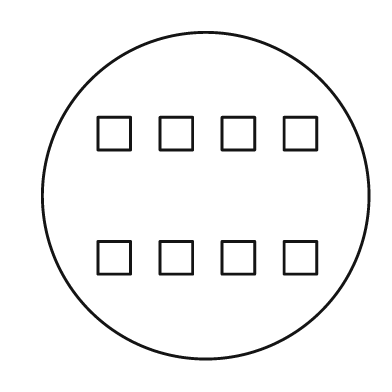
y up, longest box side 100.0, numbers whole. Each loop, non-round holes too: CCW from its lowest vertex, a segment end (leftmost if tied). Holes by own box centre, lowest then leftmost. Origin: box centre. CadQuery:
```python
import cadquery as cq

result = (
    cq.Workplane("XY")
    .moveTo(0.0, 0.0)
    .circle(50.0)
    .moveTo(-33.0, -24.0)
    .lineTo(-23.0, -24.0)
    .lineTo(-23.0, -14.0)
    .lineTo(-33.0, -14.0)
    .close()
    .moveTo(-14.0, -24.0)
    .lineTo(-4.0, -24.0)
    .lineTo(-4.0, -14.0)
    .lineTo(-14.0, -14.0)
    .close()
    .moveTo(5.0, -24.0)
    .lineTo(15.0, -24.0)
    .lineTo(15.0, -14.0)
    .lineTo(5.0, -14.0)
    .close()
    .moveTo(24.0, -24.0)
    .lineTo(34.0, -24.0)
    .lineTo(34.0, -14.0)
    .lineTo(24.0, -14.0)
    .close()
    .moveTo(-33.0, 14.0)
    .lineTo(-23.0, 14.0)
    .lineTo(-23.0, 24.0)
    .lineTo(-33.0, 24.0)
    .close()
    .moveTo(-14.0, 14.0)
    .lineTo(-4.0, 14.0)
    .lineTo(-4.0, 24.0)
    .lineTo(-14.0, 24.0)
    .close()
    .moveTo(5.0, 14.0)
    .lineTo(15.0, 14.0)
    .lineTo(15.0, 24.0)
    .lineTo(5.0, 24.0)
    .close()
    .moveTo(24.0, 14.0)
    .lineTo(34.0, 14.0)
    .lineTo(34.0, 24.0)
    .lineTo(24.0, 24.0)
    .close()
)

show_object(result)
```